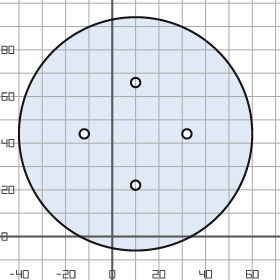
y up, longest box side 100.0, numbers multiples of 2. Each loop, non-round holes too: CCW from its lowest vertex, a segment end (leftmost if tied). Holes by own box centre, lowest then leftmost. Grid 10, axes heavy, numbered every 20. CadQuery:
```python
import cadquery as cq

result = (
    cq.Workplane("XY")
    .moveTo(10.0, 44.0)
    .circle(50.0)
    .moveTo(10.0, 22.0)
    .circle(2.0)
    .moveTo(-12.0, 44.0)
    .circle(2.0)
    .moveTo(32.0, 44.0)
    .circle(2.0)
    .moveTo(10.0, 66.0)
    .circle(2.0)
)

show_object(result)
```